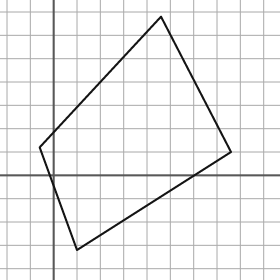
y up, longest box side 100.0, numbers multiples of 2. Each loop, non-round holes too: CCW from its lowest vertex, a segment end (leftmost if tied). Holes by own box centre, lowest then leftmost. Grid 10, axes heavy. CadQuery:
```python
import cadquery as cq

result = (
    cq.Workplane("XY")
    .moveTo(10.0, -32.0)
    .lineTo(76.0, 10.0)
    .lineTo(46.0, 68.0)
    .lineTo(-6.0, 12.0)
    .close()
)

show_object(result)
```